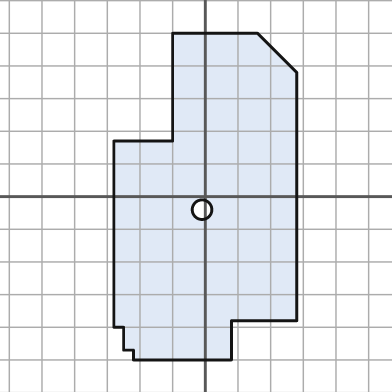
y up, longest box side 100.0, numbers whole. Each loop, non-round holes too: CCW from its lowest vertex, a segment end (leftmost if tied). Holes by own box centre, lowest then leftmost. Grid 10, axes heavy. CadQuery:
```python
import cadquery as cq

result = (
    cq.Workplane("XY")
    .moveTo(-22.0, -50.0)
    .lineTo(8.0, -50.0)
    .lineTo(8.0, -38.0)
    .lineTo(28.0, -38.0)
    .lineTo(28.0, 38.0)
    .lineTo(16.0, 50.0)
    .lineTo(-10.0, 50.0)
    .lineTo(-10.0, 17.0)
    .lineTo(-28.0, 17.0)
    .lineTo(-28.0, -40.0)
    .lineTo(-25.0, -40.0)
    .lineTo(-25.0, -47.0)
    .lineTo(-22.0, -47.0)
    .close()
    .moveTo(-1.0, -4.0)
    .circle(3.0)
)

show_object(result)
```